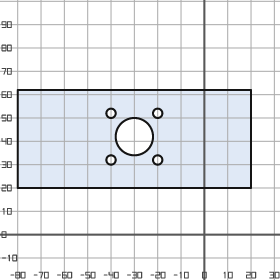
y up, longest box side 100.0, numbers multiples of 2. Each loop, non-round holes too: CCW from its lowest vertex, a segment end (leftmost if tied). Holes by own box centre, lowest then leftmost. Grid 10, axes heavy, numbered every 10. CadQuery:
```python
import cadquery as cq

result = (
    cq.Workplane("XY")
    .moveTo(-80.0, 20.0)
    .lineTo(20.0, 20.0)
    .lineTo(20.0, 62.0)
    .lineTo(-80.0, 62.0)
    .close()
    .moveTo(-40.0, 32.0)
    .circle(2.0)
    .moveTo(-20.0, 32.0)
    .circle(2.0)
    .moveTo(-30.0, 42.0)
    .circle(8.0)
    .moveTo(-40.0, 52.0)
    .circle(2.0)
    .moveTo(-20.0, 52.0)
    .circle(2.0)
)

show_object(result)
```